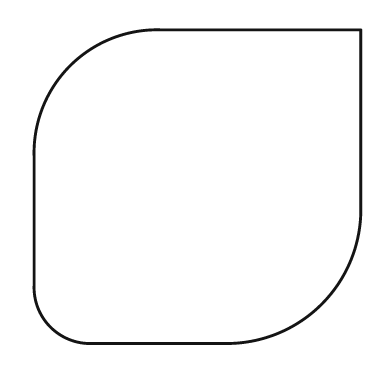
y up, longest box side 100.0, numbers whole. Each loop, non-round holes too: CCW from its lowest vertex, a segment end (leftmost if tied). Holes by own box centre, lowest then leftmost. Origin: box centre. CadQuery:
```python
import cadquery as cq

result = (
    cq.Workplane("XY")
    .moveTo(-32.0, -48.0)
    .lineTo(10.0, -48.0)
    .threePointArc((38.0, -36.0), (50.0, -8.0))
    .lineTo(50.0, 48.0)
    .lineTo(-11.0, 48.0)
    .threePointArc((-39.0, 37.0), (-50.0, 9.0))
    .lineTo(-50.0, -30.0)
    .threePointArc((-45.0, -43.0), (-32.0, -48.0))
    .close()
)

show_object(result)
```